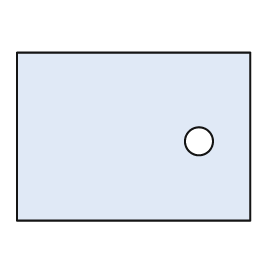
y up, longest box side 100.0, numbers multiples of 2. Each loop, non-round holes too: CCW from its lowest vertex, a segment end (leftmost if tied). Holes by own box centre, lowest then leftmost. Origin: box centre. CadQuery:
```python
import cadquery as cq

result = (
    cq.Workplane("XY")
    .moveTo(-50.0, -36.0)
    .lineTo(50.0, -36.0)
    .lineTo(50.0, 36.0)
    .lineTo(-50.0, 36.0)
    .close()
    .moveTo(28.0, -2.0)
    .circle(6.0)
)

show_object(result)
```